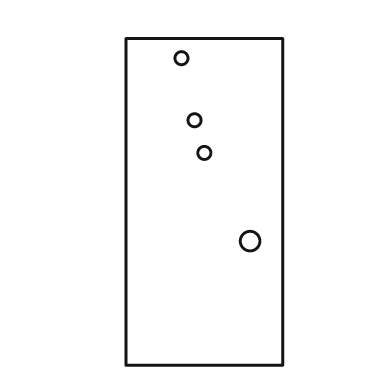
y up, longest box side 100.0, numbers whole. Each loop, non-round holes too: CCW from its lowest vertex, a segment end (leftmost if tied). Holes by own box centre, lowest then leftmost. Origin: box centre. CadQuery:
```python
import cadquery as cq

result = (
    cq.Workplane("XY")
    .moveTo(-24.0, -50.0)
    .lineTo(24.0, -50.0)
    .lineTo(24.0, 50.0)
    .lineTo(-24.0, 50.0)
    .close()
    .moveTo(14.0, -12.0)
    .circle(3.0)
    .moveTo(0.0, 15.0)
    .circle(2.0)
    .moveTo(-3.0, 25.0)
    .circle(2.0)
    .moveTo(-7.0, 44.0)
    .circle(2.0)
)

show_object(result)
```